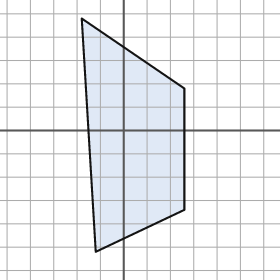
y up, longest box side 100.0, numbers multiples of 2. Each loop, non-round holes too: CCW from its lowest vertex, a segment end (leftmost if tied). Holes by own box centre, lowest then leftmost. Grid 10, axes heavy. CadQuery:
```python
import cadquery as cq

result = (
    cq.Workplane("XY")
    .moveTo(-12.0, -52.0)
    .lineTo(26.0, -34.0)
    .lineTo(26.0, 18.0)
    .lineTo(-18.0, 48.0)
    .close()
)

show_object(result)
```